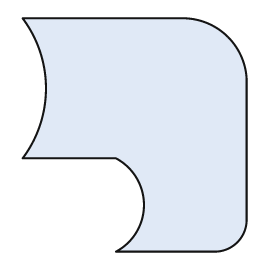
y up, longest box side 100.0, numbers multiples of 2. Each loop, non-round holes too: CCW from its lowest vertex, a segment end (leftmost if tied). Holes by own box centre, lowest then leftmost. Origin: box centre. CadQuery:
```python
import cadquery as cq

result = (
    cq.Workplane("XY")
    .moveTo(-8.0, -50.0)
    .lineTo(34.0, -50.0)
    .threePointArc((44.0, -46.0), (48.0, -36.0))
    .lineTo(48.0, 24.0)
    .threePointArc((40.0, 42.0), (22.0, 50.0))
    .lineTo(-48.0, 50.0)
    .threePointArc((-38.0, 20.0), (-48.0, -10.0))
    .lineTo(-8.0, -10.0)
    .threePointArc((4.0, -30.0), (-8.0, -50.0))
    .close()
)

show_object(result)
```